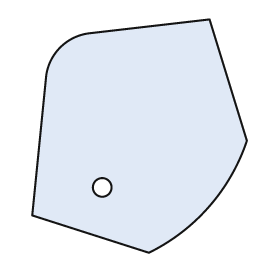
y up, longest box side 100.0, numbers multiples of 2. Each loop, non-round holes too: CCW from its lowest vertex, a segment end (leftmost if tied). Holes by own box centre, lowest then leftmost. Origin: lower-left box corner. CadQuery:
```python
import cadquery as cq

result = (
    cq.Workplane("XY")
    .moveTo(50.0, 0.0)
    .threePointArc((76.0, 20.0), (92.0, 48.0))
    .lineTo(76.0, 100.0)
    .lineTo(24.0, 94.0)
    .threePointArc((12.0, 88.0), (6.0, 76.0))
    .lineTo(0.0, 16.0)
    .close()
    .moveTo(30.0, 28.0)
    .circle(4.0)
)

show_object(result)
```